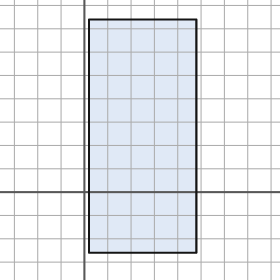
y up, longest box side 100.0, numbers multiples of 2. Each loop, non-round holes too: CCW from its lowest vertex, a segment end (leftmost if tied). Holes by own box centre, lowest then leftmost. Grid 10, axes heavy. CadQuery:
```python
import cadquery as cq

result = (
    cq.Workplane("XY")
    .moveTo(2.0, -26.0)
    .lineTo(48.0, -26.0)
    .lineTo(48.0, 74.0)
    .lineTo(2.0, 74.0)
    .close()
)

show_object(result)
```